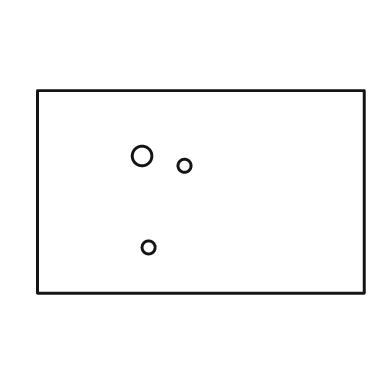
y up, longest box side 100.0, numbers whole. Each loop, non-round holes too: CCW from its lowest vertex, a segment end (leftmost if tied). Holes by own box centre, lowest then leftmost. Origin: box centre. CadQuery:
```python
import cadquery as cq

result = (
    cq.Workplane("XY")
    .moveTo(-50.0, -31.0)
    .lineTo(50.0, -31.0)
    .lineTo(50.0, 31.0)
    .lineTo(-50.0, 31.0)
    .close()
    .moveTo(-16.0, -17.0)
    .circle(2.0)
    .moveTo(-5.0, 8.0)
    .circle(2.0)
    .moveTo(-18.0, 11.0)
    .circle(3.0)
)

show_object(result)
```